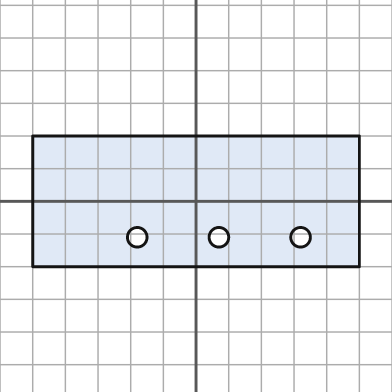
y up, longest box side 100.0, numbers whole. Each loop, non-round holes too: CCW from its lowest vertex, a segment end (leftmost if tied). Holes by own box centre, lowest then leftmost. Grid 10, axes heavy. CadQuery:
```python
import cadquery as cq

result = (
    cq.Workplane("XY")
    .moveTo(-50.0, -20.0)
    .lineTo(50.0, -20.0)
    .lineTo(50.0, 20.0)
    .lineTo(-50.0, 20.0)
    .close()
    .moveTo(-18.0, -11.0)
    .circle(3.0)
    .moveTo(7.0, -11.0)
    .circle(3.0)
    .moveTo(32.0, -11.0)
    .circle(3.0)
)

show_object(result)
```